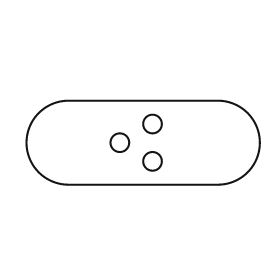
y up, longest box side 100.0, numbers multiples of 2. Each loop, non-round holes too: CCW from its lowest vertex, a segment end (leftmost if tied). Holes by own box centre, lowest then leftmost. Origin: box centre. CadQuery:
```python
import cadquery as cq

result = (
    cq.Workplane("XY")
    .moveTo(-32.0, -18.0)
    .lineTo(32.0, -18.0)
    .threePointArc((50.0, 0.0), (32.0, 18.0))
    .lineTo(-32.0, 18.0)
    .threePointArc((-50.0, 0.0), (-32.0, -18.0))
    .close()
    .moveTo(4.0, -8.0)
    .circle(4.0)
    .moveTo(-10.0, 0.0)
    .circle(4.0)
    .moveTo(4.0, 8.0)
    .circle(4.0)
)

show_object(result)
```